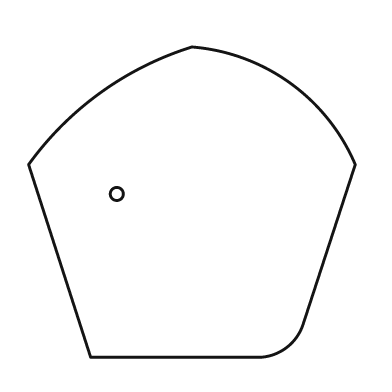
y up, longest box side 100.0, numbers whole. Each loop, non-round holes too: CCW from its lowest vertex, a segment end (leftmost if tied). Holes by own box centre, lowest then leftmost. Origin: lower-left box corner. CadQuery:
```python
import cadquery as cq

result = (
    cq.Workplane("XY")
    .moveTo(19.0, 0.0)
    .lineTo(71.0, 0.0)
    .threePointArc((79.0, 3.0), (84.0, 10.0))
    .lineTo(100.0, 59.0)
    .threePointArc((80.0, 84.0), (50.0, 95.0))
    .threePointArc((22.0, 81.0), (0.0, 59.0))
    .close()
    .moveTo(27.0, 50.0)
    .circle(2.0)
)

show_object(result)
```